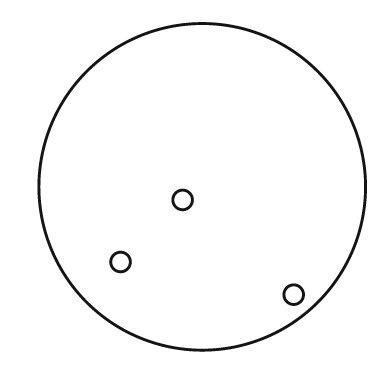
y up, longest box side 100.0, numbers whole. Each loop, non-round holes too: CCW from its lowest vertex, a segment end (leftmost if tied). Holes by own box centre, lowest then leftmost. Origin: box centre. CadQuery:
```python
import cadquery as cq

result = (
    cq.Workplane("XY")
    .moveTo(0.0, 0.0)
    .circle(50.0)
    .moveTo(28.0, -33.0)
    .circle(3.0)
    .moveTo(-25.0, -23.0)
    .circle(3.0)
    .moveTo(-6.0, -4.0)
    .circle(3.0)
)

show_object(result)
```